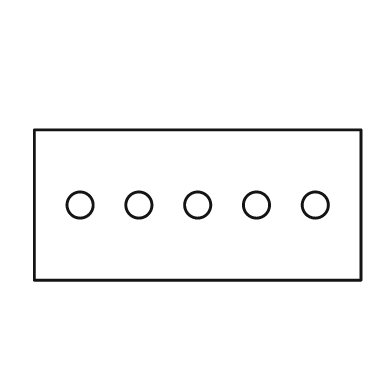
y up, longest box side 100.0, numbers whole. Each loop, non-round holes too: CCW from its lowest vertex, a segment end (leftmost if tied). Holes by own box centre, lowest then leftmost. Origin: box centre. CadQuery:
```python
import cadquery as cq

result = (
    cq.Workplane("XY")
    .moveTo(-50.0, -23.0)
    .lineTo(50.0, -23.0)
    .lineTo(50.0, 23.0)
    .lineTo(-50.0, 23.0)
    .close()
    .moveTo(-36.0, 0.0)
    .circle(4.0)
    .moveTo(-18.0, 0.0)
    .circle(4.0)
    .moveTo(0.0, 0.0)
    .circle(4.0)
    .moveTo(18.0, 0.0)
    .circle(4.0)
    .moveTo(36.0, 0.0)
    .circle(4.0)
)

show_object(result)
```